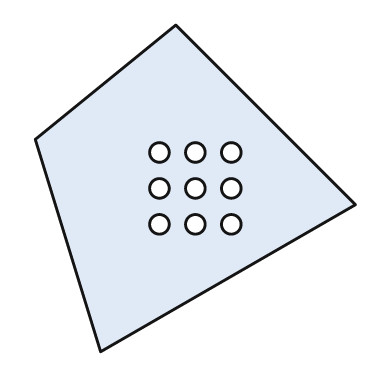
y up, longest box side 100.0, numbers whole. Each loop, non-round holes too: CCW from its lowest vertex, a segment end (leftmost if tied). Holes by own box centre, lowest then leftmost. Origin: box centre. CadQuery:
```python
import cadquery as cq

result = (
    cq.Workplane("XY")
    .moveTo(-29.0, -50.0)
    .lineTo(49.0, -5.0)
    .lineTo(-6.0, 50.0)
    .lineTo(-49.0, 15.0)
    .close()
    .moveTo(-11.0, -11.0)
    .circle(3.0)
    .moveTo(0.0, -11.0)
    .circle(3.0)
    .moveTo(11.0, -11.0)
    .circle(3.0)
    .moveTo(-11.0, 0.0)
    .circle(3.0)
    .moveTo(0.0, 0.0)
    .circle(3.0)
    .moveTo(11.0, 0.0)
    .circle(3.0)
    .moveTo(-11.0, 11.0)
    .circle(3.0)
    .moveTo(0.0, 11.0)
    .circle(3.0)
    .moveTo(11.0, 11.0)
    .circle(3.0)
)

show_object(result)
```